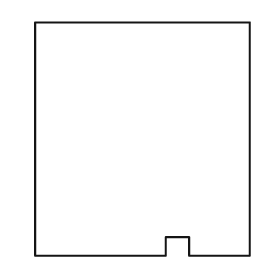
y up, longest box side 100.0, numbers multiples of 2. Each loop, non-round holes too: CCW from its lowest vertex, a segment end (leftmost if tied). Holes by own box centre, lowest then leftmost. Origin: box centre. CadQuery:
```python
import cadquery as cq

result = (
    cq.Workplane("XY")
    .moveTo(-46.0, -50.0)
    .lineTo(10.0, -50.0)
    .lineTo(10.0, -42.0)
    .lineTo(20.0, -42.0)
    .lineTo(20.0, -50.0)
    .lineTo(46.0, -50.0)
    .lineTo(46.0, 50.0)
    .lineTo(-46.0, 50.0)
    .close()
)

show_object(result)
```